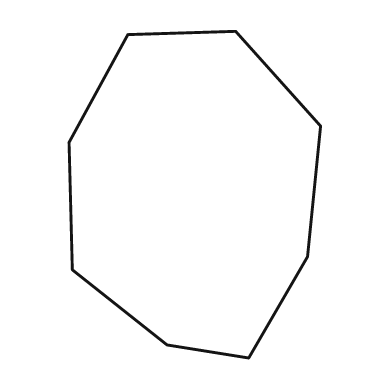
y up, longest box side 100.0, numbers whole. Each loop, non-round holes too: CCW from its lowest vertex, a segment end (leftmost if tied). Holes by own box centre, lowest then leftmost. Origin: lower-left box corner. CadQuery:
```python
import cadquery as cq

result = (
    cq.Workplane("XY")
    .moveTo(55.0, 0.0)
    .lineTo(73.0, 31.0)
    .lineTo(77.0, 71.0)
    .lineTo(51.0, 100.0)
    .lineTo(18.0, 99.0)
    .lineTo(0.0, 66.0)
    .lineTo(1.0, 27.0)
    .lineTo(30.0, 4.0)
    .close()
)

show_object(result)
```